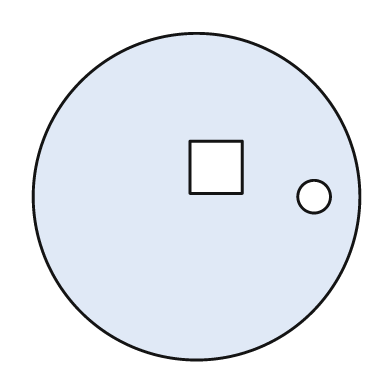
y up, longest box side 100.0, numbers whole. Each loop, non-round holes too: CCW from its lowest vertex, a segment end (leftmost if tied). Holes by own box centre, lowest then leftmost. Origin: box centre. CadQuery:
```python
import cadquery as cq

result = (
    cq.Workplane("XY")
    .moveTo(0.0, 0.0)
    .circle(50.0)
    .moveTo(36.0, 0.0)
    .circle(5.0)
    .moveTo(-2.0, 1.0)
    .lineTo(14.0, 1.0)
    .lineTo(14.0, 17.0)
    .lineTo(-2.0, 17.0)
    .close()
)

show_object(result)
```